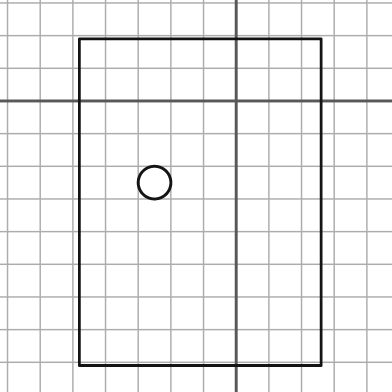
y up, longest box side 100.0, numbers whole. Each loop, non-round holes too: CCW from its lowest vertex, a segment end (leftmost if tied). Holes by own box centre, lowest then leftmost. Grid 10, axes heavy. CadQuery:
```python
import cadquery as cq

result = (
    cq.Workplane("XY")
    .moveTo(-48.0, -81.0)
    .lineTo(26.0, -81.0)
    .lineTo(26.0, 19.0)
    .lineTo(-48.0, 19.0)
    .close()
    .moveTo(-25.0, -25.0)
    .circle(5.0)
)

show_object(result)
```